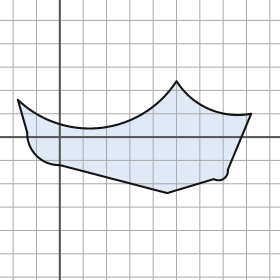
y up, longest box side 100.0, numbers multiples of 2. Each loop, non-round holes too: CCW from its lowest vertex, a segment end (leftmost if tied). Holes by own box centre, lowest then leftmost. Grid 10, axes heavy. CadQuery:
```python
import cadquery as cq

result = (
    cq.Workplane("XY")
    .moveTo(46.0, -24.0)
    .lineTo(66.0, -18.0)
    .threePointArc((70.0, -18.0), (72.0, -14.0))
    .lineTo(82.0, 10.0)
    .threePointArc((64.0, 12.0), (50.0, 24.0))
    .threePointArc((18.0, 4.0), (-18.0, 16.0))
    .lineTo(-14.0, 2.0)
    .threePointArc((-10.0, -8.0), (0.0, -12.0))
    .close()
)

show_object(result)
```